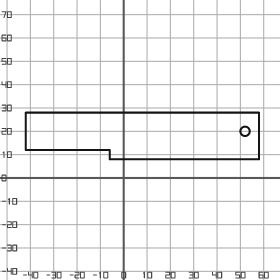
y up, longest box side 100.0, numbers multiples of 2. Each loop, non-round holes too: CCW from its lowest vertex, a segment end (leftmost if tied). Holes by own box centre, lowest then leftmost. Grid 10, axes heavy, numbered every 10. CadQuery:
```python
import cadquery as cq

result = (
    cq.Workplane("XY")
    .moveTo(-6.0, 8.0)
    .lineTo(58.0, 8.0)
    .lineTo(58.0, 28.0)
    .lineTo(-42.0, 28.0)
    .lineTo(-42.0, 12.0)
    .lineTo(-6.0, 12.0)
    .close()
    .moveTo(52.0, 20.0)
    .circle(2.0)
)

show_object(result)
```